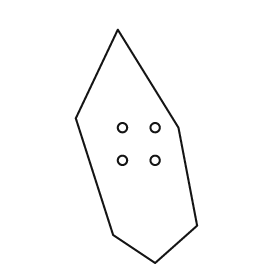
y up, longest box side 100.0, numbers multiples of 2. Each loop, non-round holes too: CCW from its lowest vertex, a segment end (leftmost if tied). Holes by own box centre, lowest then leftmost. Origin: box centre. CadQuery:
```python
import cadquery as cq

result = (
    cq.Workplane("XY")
    .moveTo(8.0, -50.0)
    .lineTo(26.0, -34.0)
    .lineTo(18.0, 8.0)
    .lineTo(-8.0, 50.0)
    .lineTo(-26.0, 12.0)
    .lineTo(-10.0, -38.0)
    .close()
    .moveTo(-6.0, -6.0)
    .circle(2.0)
    .moveTo(8.0, -6.0)
    .circle(2.0)
    .moveTo(-6.0, 8.0)
    .circle(2.0)
    .moveTo(8.0, 8.0)
    .circle(2.0)
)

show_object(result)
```